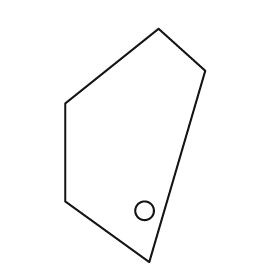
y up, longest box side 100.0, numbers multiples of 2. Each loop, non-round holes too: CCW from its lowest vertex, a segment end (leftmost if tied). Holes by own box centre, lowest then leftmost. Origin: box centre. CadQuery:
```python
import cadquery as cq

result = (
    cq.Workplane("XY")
    .moveTo(6.0, -50.0)
    .lineTo(30.0, 32.0)
    .lineTo(10.0, 50.0)
    .lineTo(-30.0, 18.0)
    .lineTo(-30.0, -24.0)
    .close()
    .moveTo(4.0, -28.0)
    .circle(4.0)
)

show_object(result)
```